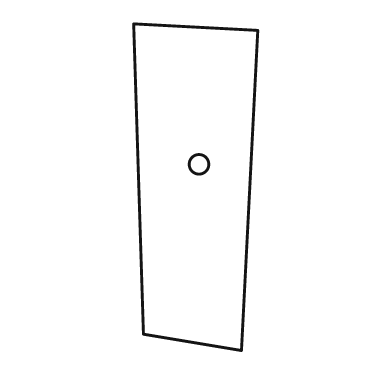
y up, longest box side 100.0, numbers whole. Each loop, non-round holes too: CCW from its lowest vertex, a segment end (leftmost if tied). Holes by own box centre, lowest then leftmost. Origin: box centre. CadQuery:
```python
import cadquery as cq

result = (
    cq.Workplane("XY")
    .moveTo(14.0, -50.0)
    .lineTo(19.0, 48.0)
    .lineTo(-19.0, 50.0)
    .lineTo(-16.0, -45.0)
    .close()
    .moveTo(1.0, 7.0)
    .circle(3.0)
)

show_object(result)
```